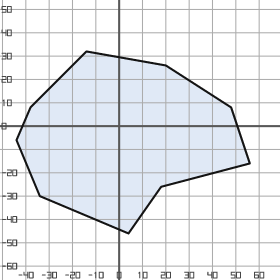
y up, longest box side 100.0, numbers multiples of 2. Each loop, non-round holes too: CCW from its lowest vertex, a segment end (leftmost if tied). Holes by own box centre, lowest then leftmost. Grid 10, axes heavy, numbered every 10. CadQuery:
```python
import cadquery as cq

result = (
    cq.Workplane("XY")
    .moveTo(4.0, -46.0)
    .lineTo(18.0, -26.0)
    .lineTo(56.0, -16.0)
    .lineTo(48.0, 8.0)
    .lineTo(20.0, 26.0)
    .lineTo(-14.0, 32.0)
    .lineTo(-38.0, 8.0)
    .lineTo(-44.0, -6.0)
    .lineTo(-34.0, -30.0)
    .close()
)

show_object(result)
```